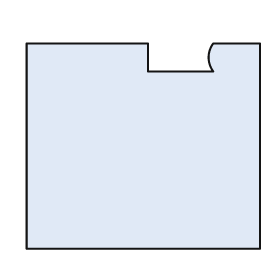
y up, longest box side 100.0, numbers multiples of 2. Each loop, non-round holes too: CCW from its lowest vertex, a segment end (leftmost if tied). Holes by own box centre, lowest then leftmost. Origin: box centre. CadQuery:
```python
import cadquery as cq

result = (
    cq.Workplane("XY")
    .moveTo(-50.0, -44.0)
    .lineTo(50.0, -44.0)
    .lineTo(50.0, 44.0)
    .lineTo(30.0, 44.0)
    .threePointArc((28.0, 38.0), (30.0, 32.0))
    .lineTo(2.0, 32.0)
    .lineTo(2.0, 44.0)
    .lineTo(-50.0, 44.0)
    .close()
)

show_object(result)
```